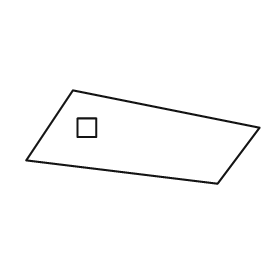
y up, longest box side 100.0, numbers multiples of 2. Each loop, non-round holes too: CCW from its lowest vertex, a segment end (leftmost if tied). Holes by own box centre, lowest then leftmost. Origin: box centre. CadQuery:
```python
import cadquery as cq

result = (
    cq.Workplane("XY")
    .moveTo(32.0, -20.0)
    .lineTo(50.0, 4.0)
    .lineTo(-30.0, 20.0)
    .lineTo(-50.0, -10.0)
    .close()
    .moveTo(-28.0, 0.0)
    .lineTo(-20.0, 0.0)
    .lineTo(-20.0, 8.0)
    .lineTo(-28.0, 8.0)
    .close()
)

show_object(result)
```